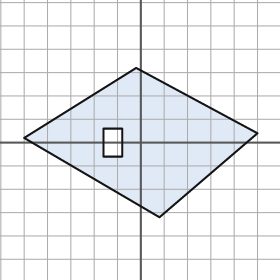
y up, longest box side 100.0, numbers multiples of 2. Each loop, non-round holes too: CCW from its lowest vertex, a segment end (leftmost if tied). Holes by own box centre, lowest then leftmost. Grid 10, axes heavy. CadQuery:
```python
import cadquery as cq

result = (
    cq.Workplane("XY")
    .moveTo(8.0, -32.0)
    .lineTo(50.0, 4.0)
    .lineTo(-2.0, 32.0)
    .lineTo(-50.0, 2.0)
    .close()
    .moveTo(-16.0, -6.0)
    .lineTo(-8.0, -6.0)
    .lineTo(-8.0, 6.0)
    .lineTo(-16.0, 6.0)
    .close()
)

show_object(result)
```